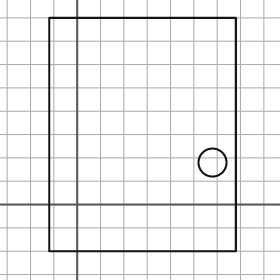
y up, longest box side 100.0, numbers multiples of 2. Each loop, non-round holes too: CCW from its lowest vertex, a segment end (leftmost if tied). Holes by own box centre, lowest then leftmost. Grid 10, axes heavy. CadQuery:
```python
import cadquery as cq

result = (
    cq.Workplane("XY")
    .moveTo(-12.0, -20.0)
    .lineTo(68.0, -20.0)
    .lineTo(68.0, 80.0)
    .lineTo(-12.0, 80.0)
    .close()
    .moveTo(58.0, 18.0)
    .circle(6.0)
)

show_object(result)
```